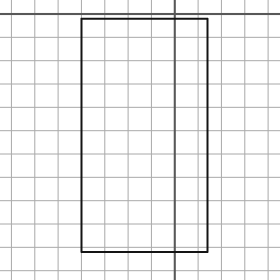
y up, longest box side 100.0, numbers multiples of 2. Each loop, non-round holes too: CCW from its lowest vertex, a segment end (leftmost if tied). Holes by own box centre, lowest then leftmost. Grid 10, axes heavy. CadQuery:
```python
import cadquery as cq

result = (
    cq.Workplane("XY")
    .moveTo(-40.0, -102.0)
    .lineTo(14.0, -102.0)
    .lineTo(14.0, -2.0)
    .lineTo(-40.0, -2.0)
    .close()
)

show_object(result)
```